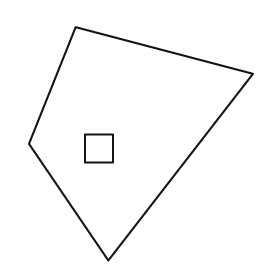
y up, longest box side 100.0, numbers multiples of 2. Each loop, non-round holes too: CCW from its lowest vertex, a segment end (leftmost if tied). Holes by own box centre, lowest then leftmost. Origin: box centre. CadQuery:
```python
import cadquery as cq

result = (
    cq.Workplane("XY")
    .moveTo(-14.0, -50.0)
    .lineTo(48.0, 30.0)
    .lineTo(-28.0, 50.0)
    .lineTo(-48.0, 0.0)
    .close()
    .moveTo(-24.0, -8.0)
    .lineTo(-12.0, -8.0)
    .lineTo(-12.0, 4.0)
    .lineTo(-24.0, 4.0)
    .close()
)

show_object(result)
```